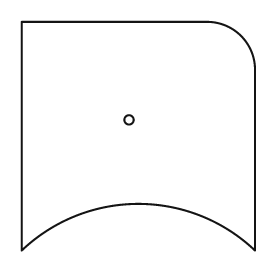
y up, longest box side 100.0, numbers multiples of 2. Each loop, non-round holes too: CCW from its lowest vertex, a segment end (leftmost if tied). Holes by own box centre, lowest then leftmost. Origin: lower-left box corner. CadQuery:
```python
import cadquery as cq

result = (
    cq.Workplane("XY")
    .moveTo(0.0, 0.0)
    .threePointArc((50.0, 20.0), (100.0, 0.0))
    .lineTo(100.0, 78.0)
    .threePointArc((94.0, 92.0), (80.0, 98.0))
    .lineTo(0.0, 98.0)
    .close()
    .moveTo(46.0, 56.0)
    .circle(2.0)
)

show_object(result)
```